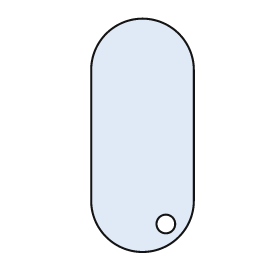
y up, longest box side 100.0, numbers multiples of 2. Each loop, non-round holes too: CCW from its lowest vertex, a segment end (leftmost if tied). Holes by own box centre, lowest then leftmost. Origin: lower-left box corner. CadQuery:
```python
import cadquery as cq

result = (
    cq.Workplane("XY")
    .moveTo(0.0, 22.0)
    .threePointArc((22.0, 0.0), (44.0, 22.0))
    .lineTo(44.0, 78.0)
    .threePointArc((22.0, 100.0), (0.0, 78.0))
    .close()
    .moveTo(32.0, 12.0)
    .circle(4.0)
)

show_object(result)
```